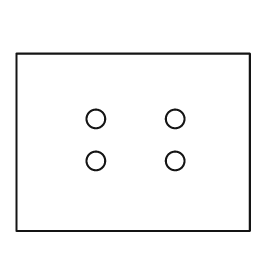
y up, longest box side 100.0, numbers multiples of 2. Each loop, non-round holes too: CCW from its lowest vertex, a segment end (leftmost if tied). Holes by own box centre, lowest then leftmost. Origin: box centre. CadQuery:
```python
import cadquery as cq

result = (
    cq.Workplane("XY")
    .moveTo(-50.0, -38.0)
    .lineTo(50.0, -38.0)
    .lineTo(50.0, 38.0)
    .lineTo(-50.0, 38.0)
    .close()
    .moveTo(-16.0, -8.0)
    .circle(4.0)
    .moveTo(18.0, -8.0)
    .circle(4.0)
    .moveTo(-16.0, 10.0)
    .circle(4.0)
    .moveTo(18.0, 10.0)
    .circle(4.0)
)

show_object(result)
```